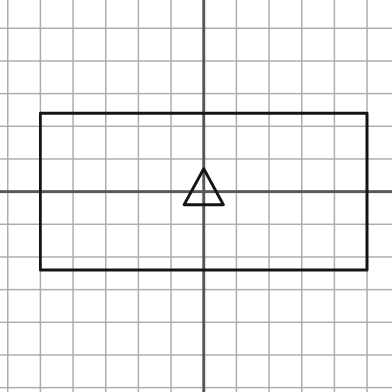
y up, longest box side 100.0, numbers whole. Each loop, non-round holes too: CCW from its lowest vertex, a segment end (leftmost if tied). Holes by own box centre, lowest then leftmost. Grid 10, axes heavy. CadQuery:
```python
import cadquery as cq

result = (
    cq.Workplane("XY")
    .moveTo(-50.0, -24.0)
    .lineTo(50.0, -24.0)
    .lineTo(50.0, 24.0)
    .lineTo(-50.0, 24.0)
    .close()
    .moveTo(-6.0, -4.0)
    .lineTo(6.0, -4.0)
    .lineTo(0.0, 7.0)
    .close()
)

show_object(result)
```